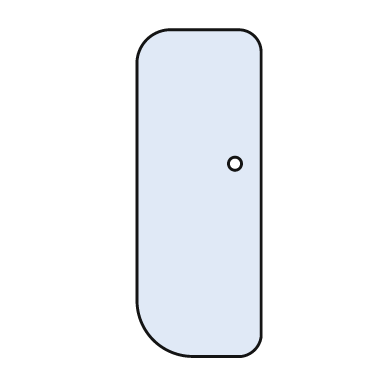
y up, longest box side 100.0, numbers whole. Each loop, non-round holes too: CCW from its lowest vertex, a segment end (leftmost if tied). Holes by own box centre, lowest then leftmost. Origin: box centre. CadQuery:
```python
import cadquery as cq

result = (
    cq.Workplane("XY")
    .moveTo(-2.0, -50.0)
    .lineTo(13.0, -50.0)
    .threePointArc((17.0, -48.0), (19.0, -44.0))
    .lineTo(19.0, 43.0)
    .threePointArc((17.0, 48.0), (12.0, 50.0))
    .lineTo(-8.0, 50.0)
    .threePointArc((-16.0, 47.0), (-19.0, 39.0))
    .lineTo(-19.0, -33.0)
    .threePointArc((-14.0, -45.0), (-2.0, -50.0))
    .close()
    .moveTo(11.0, 9.0)
    .circle(2.0)
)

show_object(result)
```